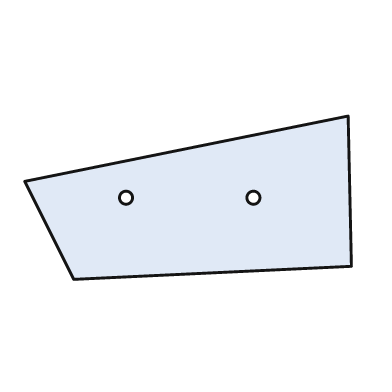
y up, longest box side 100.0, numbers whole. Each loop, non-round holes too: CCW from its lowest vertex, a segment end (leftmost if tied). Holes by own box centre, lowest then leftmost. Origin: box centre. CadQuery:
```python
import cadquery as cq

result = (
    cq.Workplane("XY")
    .moveTo(-35.0, -25.0)
    .lineTo(50.0, -21.0)
    .lineTo(49.0, 25.0)
    .lineTo(-50.0, 5.0)
    .close()
    .moveTo(-19.0, 0.0)
    .circle(2.0)
    .moveTo(20.0, 0.0)
    .circle(2.0)
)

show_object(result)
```